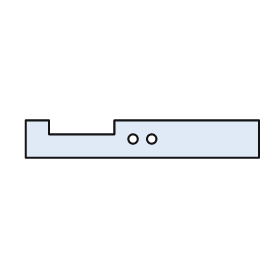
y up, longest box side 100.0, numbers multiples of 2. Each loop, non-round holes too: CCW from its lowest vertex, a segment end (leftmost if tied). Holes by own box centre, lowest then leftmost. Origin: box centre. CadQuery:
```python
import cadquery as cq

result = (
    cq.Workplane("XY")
    .moveTo(-50.0, -8.0)
    .lineTo(50.0, -8.0)
    .lineTo(50.0, 8.0)
    .lineTo(-12.0, 8.0)
    .lineTo(-12.0, 2.0)
    .lineTo(-40.0, 2.0)
    .lineTo(-40.0, 8.0)
    .lineTo(-50.0, 8.0)
    .close()
    .moveTo(-4.0, 0.0)
    .circle(2.0)
    .moveTo(4.0, 0.0)
    .circle(2.0)
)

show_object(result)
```